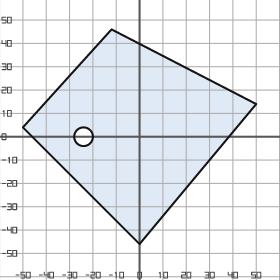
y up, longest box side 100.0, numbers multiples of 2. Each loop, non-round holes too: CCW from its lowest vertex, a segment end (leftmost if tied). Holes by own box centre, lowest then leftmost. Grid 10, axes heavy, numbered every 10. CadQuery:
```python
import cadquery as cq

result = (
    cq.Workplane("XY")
    .moveTo(0.0, -46.0)
    .lineTo(50.0, 14.0)
    .lineTo(-12.0, 46.0)
    .lineTo(-50.0, 4.0)
    .close()
    .moveTo(-24.0, 0.0)
    .circle(4.0)
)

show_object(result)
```